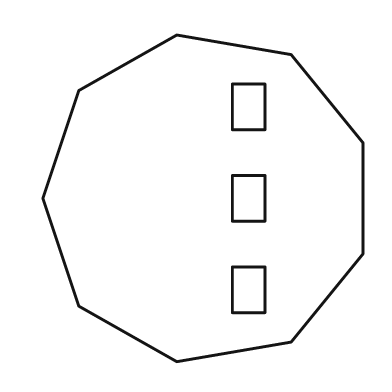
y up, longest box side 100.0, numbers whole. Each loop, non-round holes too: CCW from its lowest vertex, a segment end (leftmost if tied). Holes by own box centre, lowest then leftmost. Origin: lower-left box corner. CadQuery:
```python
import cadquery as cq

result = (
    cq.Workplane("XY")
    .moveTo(41.0, 0.0)
    .lineTo(76.0, 6.0)
    .lineTo(98.0, 33.0)
    .lineTo(98.0, 67.0)
    .lineTo(76.0, 94.0)
    .lineTo(41.0, 100.0)
    .lineTo(11.0, 83.0)
    .lineTo(0.0, 50.0)
    .lineTo(11.0, 17.0)
    .close()
    .moveTo(58.0, 15.0)
    .lineTo(68.0, 15.0)
    .lineTo(68.0, 29.0)
    .lineTo(58.0, 29.0)
    .close()
    .moveTo(58.0, 43.0)
    .lineTo(68.0, 43.0)
    .lineTo(68.0, 57.0)
    .lineTo(58.0, 57.0)
    .close()
    .moveTo(58.0, 71.0)
    .lineTo(68.0, 71.0)
    .lineTo(68.0, 85.0)
    .lineTo(58.0, 85.0)
    .close()
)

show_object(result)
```